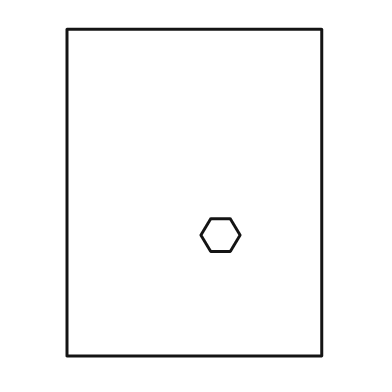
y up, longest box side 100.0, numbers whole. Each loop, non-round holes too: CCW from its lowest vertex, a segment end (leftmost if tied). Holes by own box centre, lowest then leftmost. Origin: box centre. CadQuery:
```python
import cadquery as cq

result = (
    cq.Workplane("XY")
    .moveTo(-39.0, -50.0)
    .lineTo(39.0, -50.0)
    .lineTo(39.0, 50.0)
    .lineTo(-39.0, 50.0)
    .close()
    .moveTo(5.0, -18.0)
    .lineTo(11.0, -18.0)
    .lineTo(14.0, -13.0)
    .lineTo(11.0, -8.0)
    .lineTo(5.0, -8.0)
    .lineTo(2.0, -13.0)
    .close()
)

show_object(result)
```